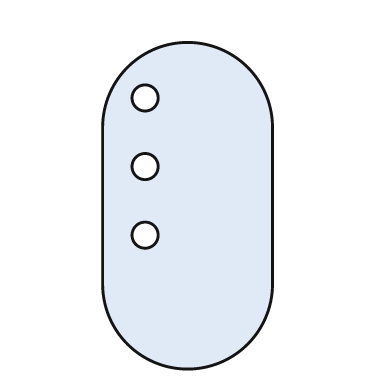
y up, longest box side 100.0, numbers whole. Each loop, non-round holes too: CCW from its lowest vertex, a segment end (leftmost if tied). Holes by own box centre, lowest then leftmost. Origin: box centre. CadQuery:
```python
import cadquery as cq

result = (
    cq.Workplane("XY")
    .moveTo(-26.0, -24.0)
    .threePointArc((0.0, -50.0), (26.0, -24.0))
    .lineTo(26.0, 24.0)
    .threePointArc((0.0, 50.0), (-26.0, 24.0))
    .close()
    .moveTo(-13.0, -9.0)
    .circle(4.0)
    .moveTo(-13.0, 12.0)
    .circle(4.0)
    .moveTo(-13.0, 33.0)
    .circle(4.0)
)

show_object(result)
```